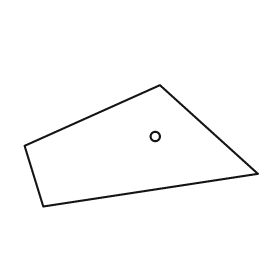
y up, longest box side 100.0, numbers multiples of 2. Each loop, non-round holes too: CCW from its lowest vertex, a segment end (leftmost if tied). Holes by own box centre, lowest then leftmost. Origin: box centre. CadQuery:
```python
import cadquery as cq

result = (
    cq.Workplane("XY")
    .moveTo(-42.0, -26.0)
    .lineTo(50.0, -12.0)
    .lineTo(8.0, 26.0)
    .lineTo(-50.0, 0.0)
    .close()
    .moveTo(6.0, 4.0)
    .circle(2.0)
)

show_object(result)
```